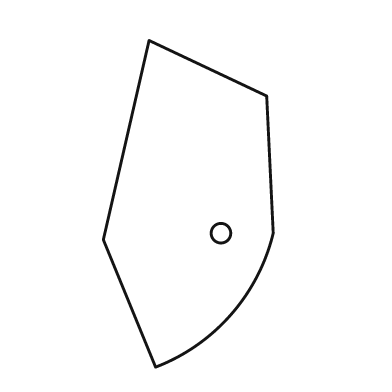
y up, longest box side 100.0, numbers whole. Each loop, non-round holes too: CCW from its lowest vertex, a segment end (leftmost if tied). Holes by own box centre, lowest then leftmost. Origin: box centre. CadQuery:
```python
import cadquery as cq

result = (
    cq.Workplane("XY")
    .moveTo(-10.0, -50.0)
    .threePointArc((13.0, -34.0), (26.0, -9.0))
    .lineTo(24.0, 33.0)
    .lineTo(-12.0, 50.0)
    .lineTo(-26.0, -11.0)
    .close()
    .moveTo(10.0, -9.0)
    .circle(3.0)
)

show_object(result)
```